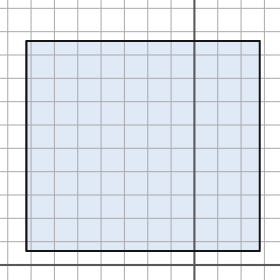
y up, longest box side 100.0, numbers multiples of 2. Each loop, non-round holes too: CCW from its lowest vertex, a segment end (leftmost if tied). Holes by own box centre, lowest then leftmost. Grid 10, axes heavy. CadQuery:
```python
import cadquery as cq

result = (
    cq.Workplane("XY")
    .moveTo(-72.0, 6.0)
    .lineTo(28.0, 6.0)
    .lineTo(28.0, 96.0)
    .lineTo(-72.0, 96.0)
    .close()
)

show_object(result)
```